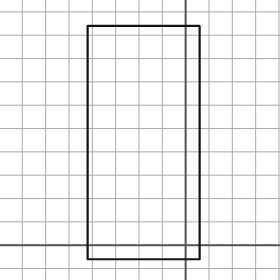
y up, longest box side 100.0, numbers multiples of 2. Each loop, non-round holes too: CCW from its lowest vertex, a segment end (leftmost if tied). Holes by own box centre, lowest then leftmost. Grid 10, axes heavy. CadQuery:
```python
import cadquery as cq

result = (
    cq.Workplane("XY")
    .moveTo(-42.0, -6.0)
    .lineTo(6.0, -6.0)
    .lineTo(6.0, 94.0)
    .lineTo(-42.0, 94.0)
    .close()
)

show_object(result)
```